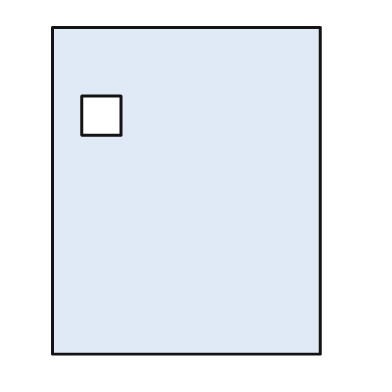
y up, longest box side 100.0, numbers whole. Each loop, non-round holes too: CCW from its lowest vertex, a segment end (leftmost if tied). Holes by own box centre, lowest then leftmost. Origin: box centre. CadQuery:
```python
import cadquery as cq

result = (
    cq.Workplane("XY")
    .moveTo(-41.0, -50.0)
    .lineTo(41.0, -50.0)
    .lineTo(41.0, 50.0)
    .lineTo(-41.0, 50.0)
    .close()
    .moveTo(-32.0, 17.0)
    .lineTo(-20.0, 17.0)
    .lineTo(-20.0, 29.0)
    .lineTo(-32.0, 29.0)
    .close()
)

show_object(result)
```